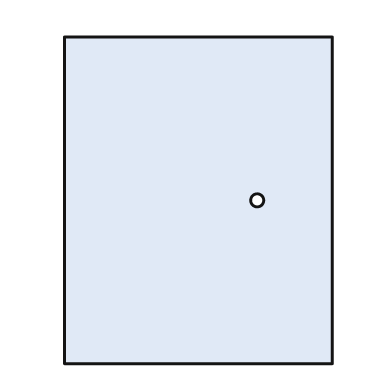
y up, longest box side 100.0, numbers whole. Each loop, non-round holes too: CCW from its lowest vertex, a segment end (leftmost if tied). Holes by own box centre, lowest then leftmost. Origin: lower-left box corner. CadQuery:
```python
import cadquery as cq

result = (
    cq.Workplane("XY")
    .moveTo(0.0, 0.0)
    .lineTo(82.0, 0.0)
    .lineTo(82.0, 100.0)
    .lineTo(0.0, 100.0)
    .close()
    .moveTo(59.0, 50.0)
    .circle(2.0)
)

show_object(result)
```